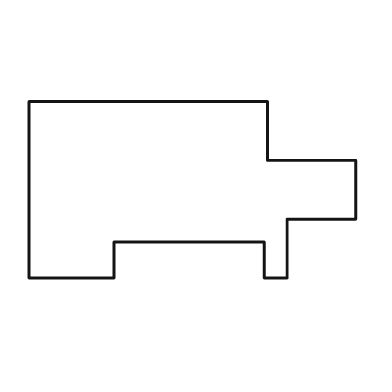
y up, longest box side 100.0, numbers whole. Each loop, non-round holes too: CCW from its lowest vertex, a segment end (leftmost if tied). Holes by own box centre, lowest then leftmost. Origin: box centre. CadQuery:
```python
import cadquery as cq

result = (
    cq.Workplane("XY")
    .moveTo(-50.0, -27.0)
    .lineTo(-24.0, -27.0)
    .lineTo(-24.0, -16.0)
    .lineTo(22.0, -16.0)
    .lineTo(22.0, -27.0)
    .lineTo(29.0, -27.0)
    .lineTo(29.0, -9.0)
    .lineTo(50.0, -9.0)
    .lineTo(50.0, 9.0)
    .lineTo(23.0, 9.0)
    .lineTo(23.0, 27.0)
    .lineTo(-50.0, 27.0)
    .close()
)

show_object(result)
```